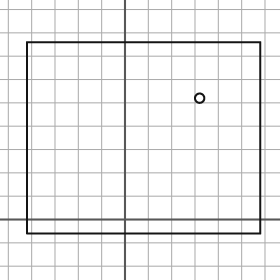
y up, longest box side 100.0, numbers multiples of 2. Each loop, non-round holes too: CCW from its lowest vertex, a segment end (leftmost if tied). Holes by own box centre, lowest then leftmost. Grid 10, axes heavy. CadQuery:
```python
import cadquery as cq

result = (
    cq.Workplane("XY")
    .moveTo(-42.0, -6.0)
    .lineTo(58.0, -6.0)
    .lineTo(58.0, 76.0)
    .lineTo(-42.0, 76.0)
    .close()
    .moveTo(32.0, 52.0)
    .circle(2.0)
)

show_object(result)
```